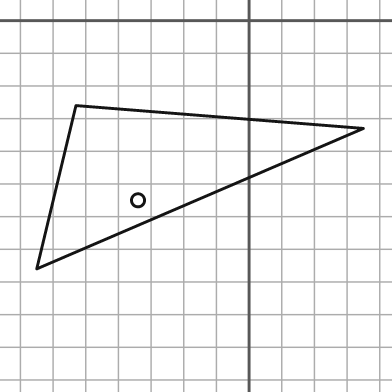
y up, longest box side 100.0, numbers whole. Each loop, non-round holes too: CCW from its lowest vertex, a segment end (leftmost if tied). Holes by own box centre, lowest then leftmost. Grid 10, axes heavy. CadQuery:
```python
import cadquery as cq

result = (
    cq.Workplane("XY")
    .moveTo(-65.0, -76.0)
    .lineTo(35.0, -33.0)
    .lineTo(-53.0, -26.0)
    .close()
    .moveTo(-34.0, -55.0)
    .circle(2.0)
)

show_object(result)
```